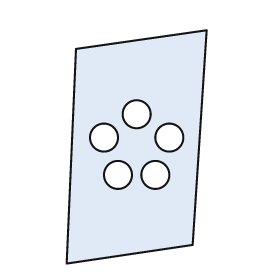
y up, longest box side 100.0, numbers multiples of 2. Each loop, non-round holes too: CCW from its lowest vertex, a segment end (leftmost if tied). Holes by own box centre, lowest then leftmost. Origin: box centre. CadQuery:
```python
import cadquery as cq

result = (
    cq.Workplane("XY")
    .moveTo(-30.0, -50.0)
    .lineTo(24.0, -42.0)
    .lineTo(30.0, 50.0)
    .lineTo(-26.0, 42.0)
    .close()
    .moveTo(-8.0, -12.0)
    .circle(6.0)
    .moveTo(8.0, -12.0)
    .circle(6.0)
    .moveTo(-14.0, 4.0)
    .circle(6.0)
    .moveTo(14.0, 4.0)
    .circle(6.0)
    .moveTo(0.0, 14.0)
    .circle(6.0)
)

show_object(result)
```